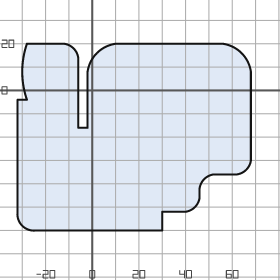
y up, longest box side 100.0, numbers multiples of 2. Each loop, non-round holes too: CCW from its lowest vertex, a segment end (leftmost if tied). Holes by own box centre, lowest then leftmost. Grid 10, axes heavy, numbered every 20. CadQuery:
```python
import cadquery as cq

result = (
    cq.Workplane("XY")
    .moveTo(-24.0, -60.0)
    .lineTo(30.0, -60.0)
    .lineTo(30.0, -52.0)
    .lineTo(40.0, -52.0)
    .threePointArc((44.0, -50.0), (46.0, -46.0))
    .lineTo(46.0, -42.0)
    .threePointArc((48.0, -38.0), (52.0, -36.0))
    .lineTo(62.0, -36.0)
    .threePointArc((66.0, -34.0), (68.0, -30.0))
    .lineTo(68.0, 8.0)
    .threePointArc((64.0, 16.0), (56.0, 20.0))
    .lineTo(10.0, 20.0)
    .threePointArc((2.0, 16.0), (-2.0, 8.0))
    .lineTo(-2.0, -16.0)
    .lineTo(-6.0, -16.0)
    .lineTo(-6.0, 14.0)
    .threePointArc((-8.0, 18.0), (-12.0, 20.0))
    .lineTo(-28.0, 20.0)
    .threePointArc((-30.0, 8.0), (-28.0, -4.0))
    .lineTo(-32.0, -4.0)
    .lineTo(-32.0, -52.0)
    .threePointArc((-30.0, -58.0), (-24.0, -60.0))
    .close()
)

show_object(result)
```